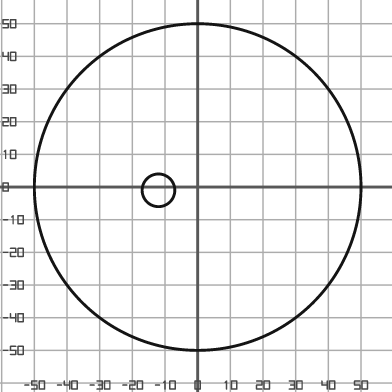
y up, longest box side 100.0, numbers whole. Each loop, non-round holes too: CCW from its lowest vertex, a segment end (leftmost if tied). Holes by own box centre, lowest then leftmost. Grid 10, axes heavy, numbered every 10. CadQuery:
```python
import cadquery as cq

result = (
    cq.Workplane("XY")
    .moveTo(0.0, 0.0)
    .circle(50.0)
    .moveTo(-12.0, -1.0)
    .circle(5.0)
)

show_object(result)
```